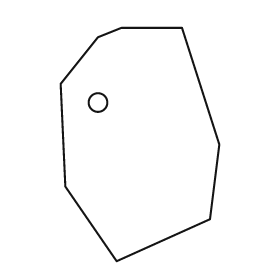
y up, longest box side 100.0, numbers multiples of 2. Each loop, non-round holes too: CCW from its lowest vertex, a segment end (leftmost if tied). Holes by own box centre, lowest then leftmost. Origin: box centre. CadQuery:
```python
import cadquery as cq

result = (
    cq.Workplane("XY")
    .moveTo(-10.0, -50.0)
    .lineTo(30.0, -32.0)
    .lineTo(34.0, 0.0)
    .lineTo(18.0, 50.0)
    .lineTo(-8.0, 50.0)
    .lineTo(-18.0, 46.0)
    .lineTo(-34.0, 26.0)
    .lineTo(-32.0, -18.0)
    .close()
    .moveTo(-18.0, 18.0)
    .circle(4.0)
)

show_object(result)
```